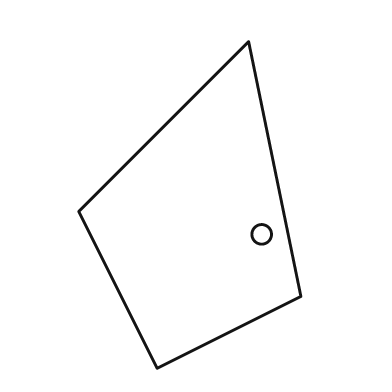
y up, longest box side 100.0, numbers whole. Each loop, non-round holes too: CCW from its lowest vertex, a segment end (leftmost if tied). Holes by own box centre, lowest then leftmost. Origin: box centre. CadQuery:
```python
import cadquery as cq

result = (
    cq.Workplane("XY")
    .moveTo(-10.0, -50.0)
    .lineTo(34.0, -28.0)
    .lineTo(18.0, 50.0)
    .lineTo(-34.0, -2.0)
    .close()
    .moveTo(22.0, -9.0)
    .circle(3.0)
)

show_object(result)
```